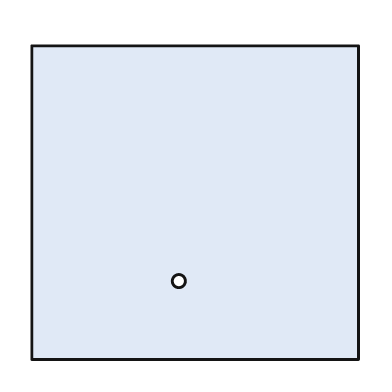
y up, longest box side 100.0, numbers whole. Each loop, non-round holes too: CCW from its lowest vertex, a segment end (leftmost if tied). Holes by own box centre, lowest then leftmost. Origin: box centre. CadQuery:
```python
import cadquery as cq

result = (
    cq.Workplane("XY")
    .moveTo(-50.0, -48.0)
    .lineTo(50.0, -48.0)
    .lineTo(50.0, 48.0)
    .lineTo(-50.0, 48.0)
    .close()
    .moveTo(-5.0, -24.0)
    .circle(2.0)
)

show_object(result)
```